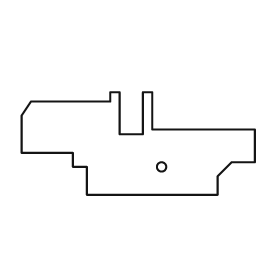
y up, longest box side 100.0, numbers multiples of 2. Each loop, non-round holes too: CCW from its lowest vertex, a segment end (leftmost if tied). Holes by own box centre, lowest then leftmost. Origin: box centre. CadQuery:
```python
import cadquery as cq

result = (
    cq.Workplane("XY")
    .moveTo(-22.0, -22.0)
    .lineTo(34.0, -22.0)
    .lineTo(34.0, -14.0)
    .lineTo(40.0, -8.0)
    .lineTo(50.0, -8.0)
    .lineTo(50.0, 6.0)
    .lineTo(6.0, 6.0)
    .lineTo(6.0, 22.0)
    .lineTo(2.0, 22.0)
    .lineTo(2.0, 4.0)
    .lineTo(-8.0, 4.0)
    .lineTo(-8.0, 22.0)
    .lineTo(-12.0, 22.0)
    .lineTo(-12.0, 18.0)
    .lineTo(-46.0, 18.0)
    .lineTo(-50.0, 12.0)
    .lineTo(-50.0, -4.0)
    .lineTo(-28.0, -4.0)
    .lineTo(-28.0, -10.0)
    .lineTo(-22.0, -10.0)
    .close()
    .moveTo(10.0, -10.0)
    .circle(2.0)
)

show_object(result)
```